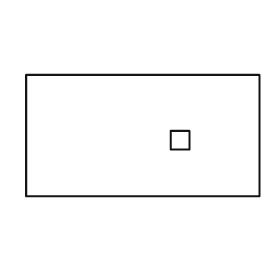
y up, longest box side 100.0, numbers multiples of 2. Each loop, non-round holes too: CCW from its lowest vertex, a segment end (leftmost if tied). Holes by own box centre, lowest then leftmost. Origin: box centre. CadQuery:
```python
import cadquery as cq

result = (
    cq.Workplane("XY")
    .moveTo(-50.0, -26.0)
    .lineTo(50.0, -26.0)
    .lineTo(50.0, 26.0)
    .lineTo(-50.0, 26.0)
    .close()
    .moveTo(12.0, -6.0)
    .lineTo(20.0, -6.0)
    .lineTo(20.0, 2.0)
    .lineTo(12.0, 2.0)
    .close()
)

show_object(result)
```